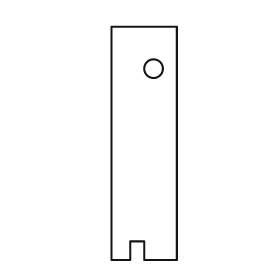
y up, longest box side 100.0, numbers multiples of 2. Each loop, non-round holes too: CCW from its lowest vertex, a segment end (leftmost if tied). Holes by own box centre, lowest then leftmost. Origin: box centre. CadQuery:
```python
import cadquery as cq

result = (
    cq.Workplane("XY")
    .moveTo(-14.0, -50.0)
    .lineTo(-6.0, -50.0)
    .lineTo(-6.0, -42.0)
    .lineTo(0.0, -42.0)
    .lineTo(0.0, -50.0)
    .lineTo(14.0, -50.0)
    .lineTo(14.0, 50.0)
    .lineTo(-14.0, 50.0)
    .close()
    .moveTo(4.0, 32.0)
    .circle(4.0)
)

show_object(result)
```